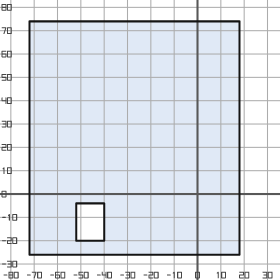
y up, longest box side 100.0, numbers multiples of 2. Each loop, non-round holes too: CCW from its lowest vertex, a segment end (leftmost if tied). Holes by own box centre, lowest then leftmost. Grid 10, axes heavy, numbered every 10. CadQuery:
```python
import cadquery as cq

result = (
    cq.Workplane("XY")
    .moveTo(-72.0, -26.0)
    .lineTo(18.0, -26.0)
    .lineTo(18.0, 74.0)
    .lineTo(-72.0, 74.0)
    .close()
    .moveTo(-52.0, -20.0)
    .lineTo(-40.0, -20.0)
    .lineTo(-40.0, -4.0)
    .lineTo(-52.0, -4.0)
    .close()
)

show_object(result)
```